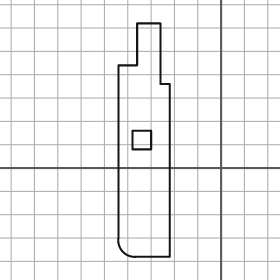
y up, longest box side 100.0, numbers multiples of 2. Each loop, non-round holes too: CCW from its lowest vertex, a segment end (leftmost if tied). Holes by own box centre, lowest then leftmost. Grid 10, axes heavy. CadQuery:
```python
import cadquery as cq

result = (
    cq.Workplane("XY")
    .moveTo(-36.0, -38.0)
    .lineTo(-22.0, -38.0)
    .lineTo(-22.0, 36.0)
    .lineTo(-26.0, 36.0)
    .lineTo(-26.0, 62.0)
    .lineTo(-36.0, 62.0)
    .lineTo(-36.0, 44.0)
    .lineTo(-44.0, 44.0)
    .lineTo(-44.0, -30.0)
    .threePointArc((-42.0, -36.0), (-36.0, -38.0))
    .close()
    .moveTo(-38.0, 8.0)
    .lineTo(-30.0, 8.0)
    .lineTo(-30.0, 16.0)
    .lineTo(-38.0, 16.0)
    .close()
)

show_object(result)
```